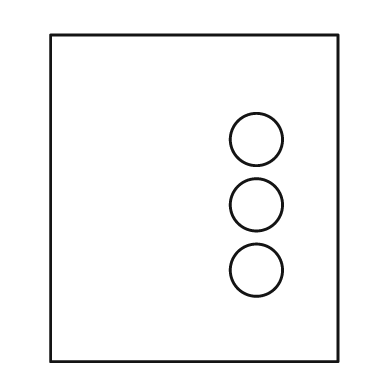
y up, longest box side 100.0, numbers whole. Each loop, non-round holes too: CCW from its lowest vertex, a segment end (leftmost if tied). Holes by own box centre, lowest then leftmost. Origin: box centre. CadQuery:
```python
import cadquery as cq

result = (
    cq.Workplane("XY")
    .moveTo(-44.0, -50.0)
    .lineTo(44.0, -50.0)
    .lineTo(44.0, 50.0)
    .lineTo(-44.0, 50.0)
    .close()
    .moveTo(19.0, -22.0)
    .circle(8.0)
    .moveTo(19.0, -2.0)
    .circle(8.0)
    .moveTo(19.0, 18.0)
    .circle(8.0)
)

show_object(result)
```